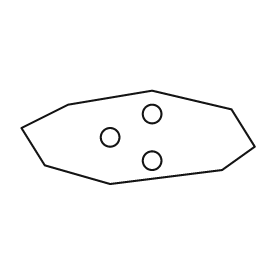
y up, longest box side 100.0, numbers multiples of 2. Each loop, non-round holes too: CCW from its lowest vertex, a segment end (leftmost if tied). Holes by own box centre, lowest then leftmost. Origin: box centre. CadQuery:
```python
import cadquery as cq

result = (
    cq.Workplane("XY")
    .moveTo(-12.0, -20.0)
    .lineTo(36.0, -14.0)
    .lineTo(50.0, -4.0)
    .lineTo(40.0, 12.0)
    .lineTo(6.0, 20.0)
    .lineTo(-30.0, 14.0)
    .lineTo(-50.0, 4.0)
    .lineTo(-40.0, -12.0)
    .close()
    .moveTo(6.0, -10.0)
    .circle(4.0)
    .moveTo(-12.0, 0.0)
    .circle(4.0)
    .moveTo(6.0, 10.0)
    .circle(4.0)
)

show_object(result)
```